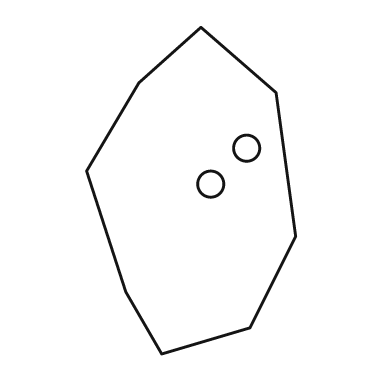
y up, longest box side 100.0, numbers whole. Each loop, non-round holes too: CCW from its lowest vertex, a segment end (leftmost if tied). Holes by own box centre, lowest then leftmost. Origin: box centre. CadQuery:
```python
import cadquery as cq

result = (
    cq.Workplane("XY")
    .moveTo(-9.0, -50.0)
    .lineTo(18.0, -42.0)
    .lineTo(32.0, -14.0)
    .lineTo(26.0, 30.0)
    .lineTo(3.0, 50.0)
    .lineTo(-16.0, 33.0)
    .lineTo(-32.0, 6.0)
    .lineTo(-20.0, -31.0)
    .close()
    .moveTo(6.0, 2.0)
    .circle(4.0)
    .moveTo(17.0, 13.0)
    .circle(4.0)
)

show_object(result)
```